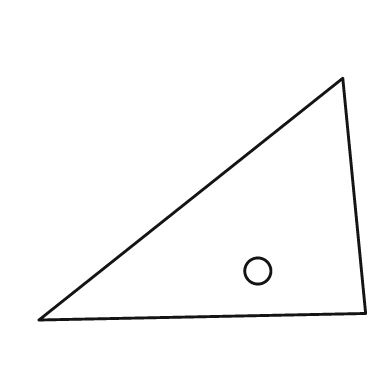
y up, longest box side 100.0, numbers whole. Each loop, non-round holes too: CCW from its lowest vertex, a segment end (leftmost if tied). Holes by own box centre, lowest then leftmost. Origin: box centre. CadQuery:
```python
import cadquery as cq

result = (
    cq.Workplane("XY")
    .moveTo(-50.0, -37.0)
    .lineTo(50.0, -35.0)
    .lineTo(43.0, 37.0)
    .close()
    .moveTo(17.0, -22.0)
    .circle(4.0)
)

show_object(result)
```